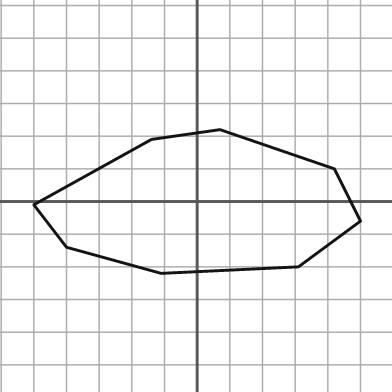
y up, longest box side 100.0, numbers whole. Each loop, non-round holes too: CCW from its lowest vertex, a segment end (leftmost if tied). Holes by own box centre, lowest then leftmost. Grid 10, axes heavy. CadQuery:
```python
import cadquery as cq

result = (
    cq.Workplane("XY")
    .moveTo(-11.0, -22.0)
    .lineTo(31.0, -20.0)
    .lineTo(50.0, -6.0)
    .lineTo(42.0, 10.0)
    .lineTo(7.0, 22.0)
    .lineTo(-14.0, 19.0)
    .lineTo(-50.0, -1.0)
    .lineTo(-40.0, -14.0)
    .close()
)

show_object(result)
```